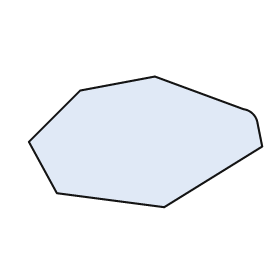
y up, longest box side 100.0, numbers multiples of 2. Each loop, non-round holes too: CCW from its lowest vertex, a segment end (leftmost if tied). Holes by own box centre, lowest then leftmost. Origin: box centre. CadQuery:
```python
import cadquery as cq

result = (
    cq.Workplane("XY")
    .moveTo(8.0, -28.0)
    .lineTo(50.0, -2.0)
    .lineTo(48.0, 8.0)
    .threePointArc((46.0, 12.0), (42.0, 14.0))
    .lineTo(4.0, 28.0)
    .lineTo(-28.0, 22.0)
    .lineTo(-50.0, 0.0)
    .lineTo(-38.0, -22.0)
    .close()
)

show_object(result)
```